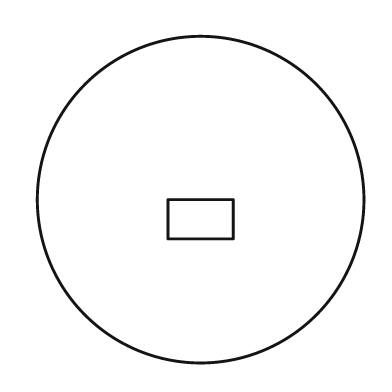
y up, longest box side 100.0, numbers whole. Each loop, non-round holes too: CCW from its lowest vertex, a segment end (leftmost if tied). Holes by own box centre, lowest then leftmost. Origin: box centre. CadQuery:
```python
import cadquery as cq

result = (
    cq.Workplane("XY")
    .moveTo(0.0, 0.0)
    .circle(50.0)
    .moveTo(-10.0, -12.0)
    .lineTo(10.0, -12.0)
    .lineTo(10.0, 0.0)
    .lineTo(-10.0, 0.0)
    .close()
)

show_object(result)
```